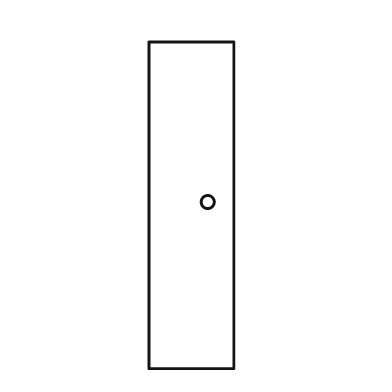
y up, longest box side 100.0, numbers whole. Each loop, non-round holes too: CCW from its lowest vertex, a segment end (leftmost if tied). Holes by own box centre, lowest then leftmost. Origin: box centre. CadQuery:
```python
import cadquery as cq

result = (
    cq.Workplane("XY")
    .moveTo(-13.0, -50.0)
    .lineTo(13.0, -50.0)
    .lineTo(13.0, 50.0)
    .lineTo(-13.0, 50.0)
    .close()
    .moveTo(5.0, 1.0)
    .circle(2.0)
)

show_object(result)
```